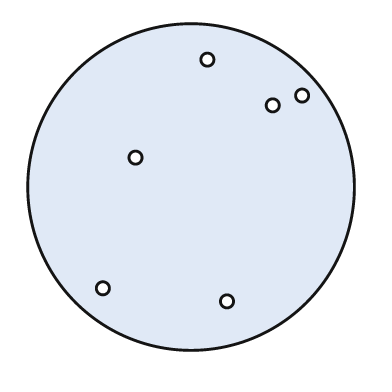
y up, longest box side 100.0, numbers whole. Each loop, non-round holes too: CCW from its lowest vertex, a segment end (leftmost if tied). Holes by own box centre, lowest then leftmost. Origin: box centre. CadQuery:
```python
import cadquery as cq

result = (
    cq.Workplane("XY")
    .moveTo(0.0, 0.0)
    .circle(50.0)
    .moveTo(11.0, -35.0)
    .circle(2.0)
    .moveTo(-27.0, -31.0)
    .circle(2.0)
    .moveTo(-17.0, 9.0)
    .circle(2.0)
    .moveTo(25.0, 25.0)
    .circle(2.0)
    .moveTo(34.0, 28.0)
    .circle(2.0)
    .moveTo(5.0, 39.0)
    .circle(2.0)
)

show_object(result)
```